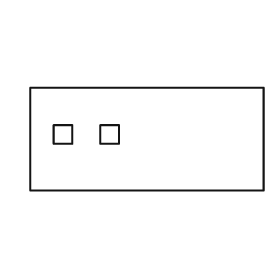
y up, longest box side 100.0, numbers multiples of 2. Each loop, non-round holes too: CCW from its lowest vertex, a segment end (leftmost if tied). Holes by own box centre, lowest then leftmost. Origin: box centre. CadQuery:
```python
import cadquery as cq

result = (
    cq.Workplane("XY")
    .moveTo(-50.0, -22.0)
    .lineTo(50.0, -22.0)
    .lineTo(50.0, 22.0)
    .lineTo(-50.0, 22.0)
    .close()
    .moveTo(-40.0, -2.0)
    .lineTo(-32.0, -2.0)
    .lineTo(-32.0, 6.0)
    .lineTo(-40.0, 6.0)
    .close()
    .moveTo(-20.0, -2.0)
    .lineTo(-12.0, -2.0)
    .lineTo(-12.0, 6.0)
    .lineTo(-20.0, 6.0)
    .close()
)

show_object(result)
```